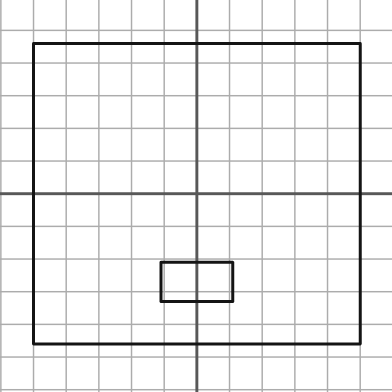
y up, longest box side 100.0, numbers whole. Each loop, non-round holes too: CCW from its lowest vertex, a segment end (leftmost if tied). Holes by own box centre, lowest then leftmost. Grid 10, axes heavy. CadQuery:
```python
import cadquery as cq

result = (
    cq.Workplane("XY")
    .moveTo(-50.0, -46.0)
    .lineTo(50.0, -46.0)
    .lineTo(50.0, 46.0)
    .lineTo(-50.0, 46.0)
    .close()
    .moveTo(-11.0, -33.0)
    .lineTo(11.0, -33.0)
    .lineTo(11.0, -21.0)
    .lineTo(-11.0, -21.0)
    .close()
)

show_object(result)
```